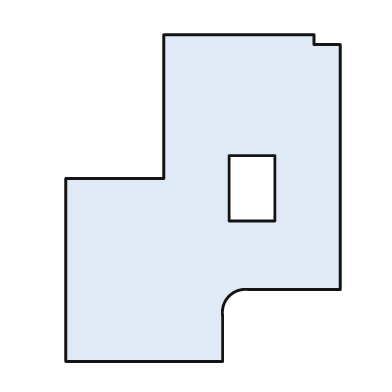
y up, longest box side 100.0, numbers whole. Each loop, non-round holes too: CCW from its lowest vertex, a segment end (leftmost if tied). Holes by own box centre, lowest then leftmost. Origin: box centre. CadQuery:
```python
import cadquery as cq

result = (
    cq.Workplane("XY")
    .moveTo(-42.0, -50.0)
    .lineTo(6.0, -50.0)
    .lineTo(6.0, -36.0)
    .threePointArc((8.0, -30.0), (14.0, -28.0))
    .lineTo(42.0, -28.0)
    .lineTo(42.0, 47.0)
    .lineTo(34.0, 47.0)
    .lineTo(34.0, 50.0)
    .lineTo(-12.0, 50.0)
    .lineTo(-12.0, 6.0)
    .lineTo(-42.0, 6.0)
    .close()
    .moveTo(8.0, -7.0)
    .lineTo(22.0, -7.0)
    .lineTo(22.0, 13.0)
    .lineTo(8.0, 13.0)
    .close()
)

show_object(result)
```